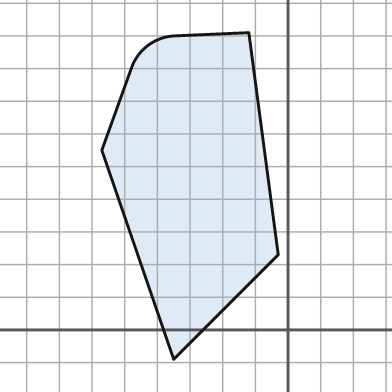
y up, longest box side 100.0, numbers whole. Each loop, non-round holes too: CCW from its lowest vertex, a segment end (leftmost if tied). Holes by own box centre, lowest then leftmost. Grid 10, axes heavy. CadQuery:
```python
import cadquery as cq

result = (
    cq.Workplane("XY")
    .moveTo(-35.0, -9.0)
    .lineTo(-3.0, 23.0)
    .lineTo(-12.0, 91.0)
    .lineTo(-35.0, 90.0)
    .threePointArc((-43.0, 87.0), (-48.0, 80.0))
    .lineTo(-57.0, 55.0)
    .close()
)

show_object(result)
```